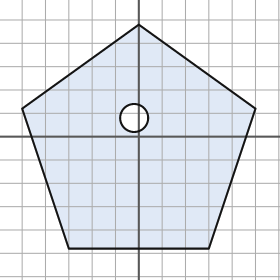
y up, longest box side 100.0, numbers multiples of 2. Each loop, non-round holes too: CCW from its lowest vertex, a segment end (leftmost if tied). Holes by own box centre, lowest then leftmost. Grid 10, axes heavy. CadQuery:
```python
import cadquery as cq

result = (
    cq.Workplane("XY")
    .moveTo(-30.0, -48.0)
    .lineTo(30.0, -48.0)
    .lineTo(50.0, 12.0)
    .lineTo(0.0, 48.0)
    .lineTo(-50.0, 12.0)
    .close()
    .moveTo(-2.0, 8.0)
    .circle(6.0)
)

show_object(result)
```